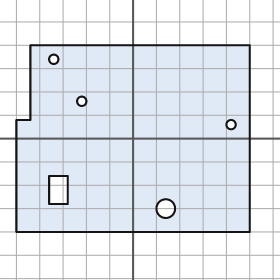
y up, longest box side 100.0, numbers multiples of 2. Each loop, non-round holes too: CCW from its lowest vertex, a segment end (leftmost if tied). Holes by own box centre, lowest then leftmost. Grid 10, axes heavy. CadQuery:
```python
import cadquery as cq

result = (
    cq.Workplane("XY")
    .moveTo(-50.0, -40.0)
    .lineTo(50.0, -40.0)
    .lineTo(50.0, 40.0)
    .lineTo(-44.0, 40.0)
    .lineTo(-44.0, 8.0)
    .lineTo(-50.0, 8.0)
    .close()
    .moveTo(14.0, -30.0)
    .circle(4.0)
    .moveTo(-36.0, -28.0)
    .lineTo(-28.0, -28.0)
    .lineTo(-28.0, -16.0)
    .lineTo(-36.0, -16.0)
    .close()
    .moveTo(42.0, 6.0)
    .circle(2.0)
    .moveTo(-22.0, 16.0)
    .circle(2.0)
    .moveTo(-34.0, 34.0)
    .circle(2.0)
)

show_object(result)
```